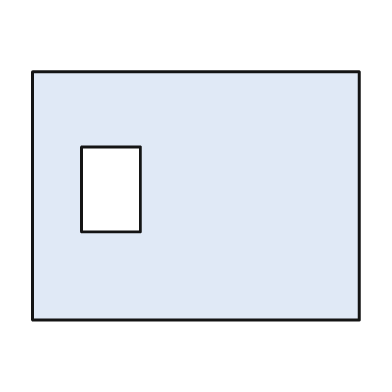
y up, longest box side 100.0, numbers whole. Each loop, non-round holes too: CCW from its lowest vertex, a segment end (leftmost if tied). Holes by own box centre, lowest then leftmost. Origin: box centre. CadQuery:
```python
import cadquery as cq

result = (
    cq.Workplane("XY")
    .moveTo(-50.0, -38.0)
    .lineTo(50.0, -38.0)
    .lineTo(50.0, 38.0)
    .lineTo(-50.0, 38.0)
    .close()
    .moveTo(-35.0, -11.0)
    .lineTo(-17.0, -11.0)
    .lineTo(-17.0, 15.0)
    .lineTo(-35.0, 15.0)
    .close()
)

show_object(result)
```